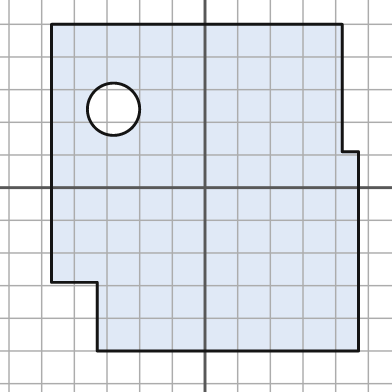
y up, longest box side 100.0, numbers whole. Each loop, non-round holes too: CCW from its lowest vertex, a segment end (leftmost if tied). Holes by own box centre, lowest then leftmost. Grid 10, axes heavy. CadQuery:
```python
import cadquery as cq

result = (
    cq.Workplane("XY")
    .moveTo(-33.0, -50.0)
    .lineTo(47.0, -50.0)
    .lineTo(47.0, 11.0)
    .lineTo(42.0, 11.0)
    .lineTo(42.0, 50.0)
    .lineTo(-47.0, 50.0)
    .lineTo(-47.0, -29.0)
    .lineTo(-33.0, -29.0)
    .close()
    .moveTo(-28.0, 24.0)
    .circle(8.0)
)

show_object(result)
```